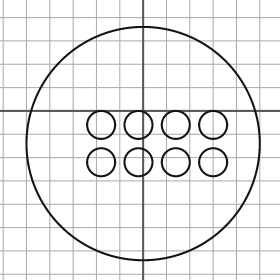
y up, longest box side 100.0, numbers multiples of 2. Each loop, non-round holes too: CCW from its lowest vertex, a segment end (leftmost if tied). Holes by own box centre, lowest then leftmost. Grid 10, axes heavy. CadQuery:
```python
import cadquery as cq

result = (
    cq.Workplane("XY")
    .moveTo(0.0, -14.0)
    .circle(50.0)
    .moveTo(-18.0, -22.0)
    .circle(6.0)
    .moveTo(-2.0, -22.0)
    .circle(6.0)
    .moveTo(14.0, -22.0)
    .circle(6.0)
    .moveTo(30.0, -22.0)
    .circle(6.0)
    .moveTo(-18.0, -6.0)
    .circle(6.0)
    .moveTo(-2.0, -6.0)
    .circle(6.0)
    .moveTo(14.0, -6.0)
    .circle(6.0)
    .moveTo(30.0, -6.0)
    .circle(6.0)
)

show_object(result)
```